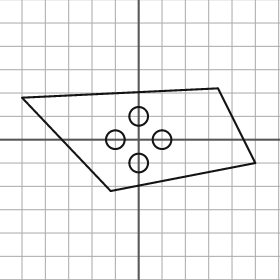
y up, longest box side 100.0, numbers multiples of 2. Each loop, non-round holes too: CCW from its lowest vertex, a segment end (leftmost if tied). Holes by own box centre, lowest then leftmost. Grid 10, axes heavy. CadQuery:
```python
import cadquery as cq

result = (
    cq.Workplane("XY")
    .moveTo(-12.0, -22.0)
    .lineTo(50.0, -10.0)
    .lineTo(34.0, 22.0)
    .lineTo(-50.0, 18.0)
    .close()
    .moveTo(0.0, -10.0)
    .circle(4.0)
    .moveTo(-10.0, 0.0)
    .circle(4.0)
    .moveTo(10.0, 0.0)
    .circle(4.0)
    .moveTo(0.0, 10.0)
    .circle(4.0)
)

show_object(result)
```